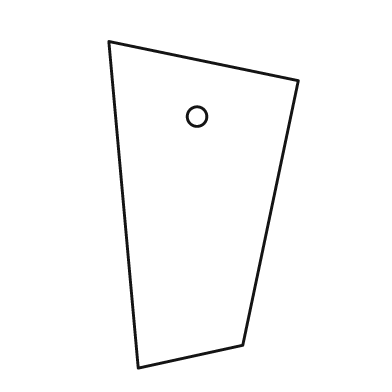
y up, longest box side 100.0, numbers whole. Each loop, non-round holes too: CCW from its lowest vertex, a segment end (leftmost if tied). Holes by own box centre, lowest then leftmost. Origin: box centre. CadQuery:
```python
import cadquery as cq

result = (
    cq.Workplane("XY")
    .moveTo(-20.0, -50.0)
    .lineTo(12.0, -43.0)
    .lineTo(29.0, 38.0)
    .lineTo(-29.0, 50.0)
    .close()
    .moveTo(-2.0, 27.0)
    .circle(3.0)
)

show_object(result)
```